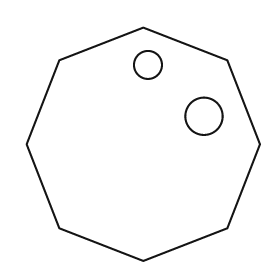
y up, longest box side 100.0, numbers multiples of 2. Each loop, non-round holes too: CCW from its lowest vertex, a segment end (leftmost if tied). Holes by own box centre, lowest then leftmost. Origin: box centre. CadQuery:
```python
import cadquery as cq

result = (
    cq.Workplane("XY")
    .moveTo(0.0, -50.0)
    .lineTo(36.0, -36.0)
    .lineTo(50.0, 0.0)
    .lineTo(36.0, 36.0)
    .lineTo(0.0, 50.0)
    .lineTo(-36.0, 36.0)
    .lineTo(-50.0, 0.0)
    .lineTo(-36.0, -36.0)
    .close()
    .moveTo(26.0, 12.0)
    .circle(8.0)
    .moveTo(2.0, 34.0)
    .circle(6.0)
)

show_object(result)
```